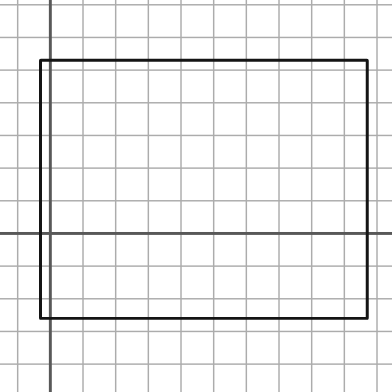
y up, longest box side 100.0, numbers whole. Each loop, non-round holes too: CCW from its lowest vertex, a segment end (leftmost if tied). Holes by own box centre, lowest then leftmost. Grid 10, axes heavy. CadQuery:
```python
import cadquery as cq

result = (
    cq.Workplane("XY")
    .moveTo(-3.0, -26.0)
    .lineTo(97.0, -26.0)
    .lineTo(97.0, 53.0)
    .lineTo(-3.0, 53.0)
    .close()
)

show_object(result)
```